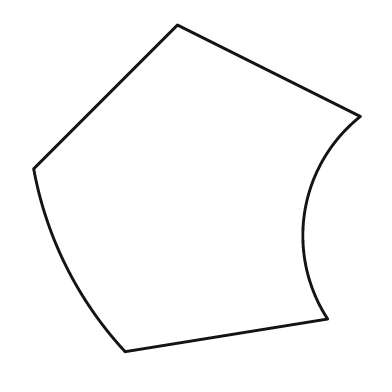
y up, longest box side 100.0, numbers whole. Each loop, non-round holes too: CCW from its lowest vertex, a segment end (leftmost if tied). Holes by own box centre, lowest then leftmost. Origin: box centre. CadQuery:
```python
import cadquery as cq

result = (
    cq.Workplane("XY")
    .moveTo(-22.0, -50.0)
    .lineTo(40.0, -40.0)
    .threePointArc((33.0, -7.0), (50.0, 22.0))
    .lineTo(-6.0, 50.0)
    .lineTo(-50.0, 6.0)
    .threePointArc((-40.0, -24.0), (-22.0, -50.0))
    .close()
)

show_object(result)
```